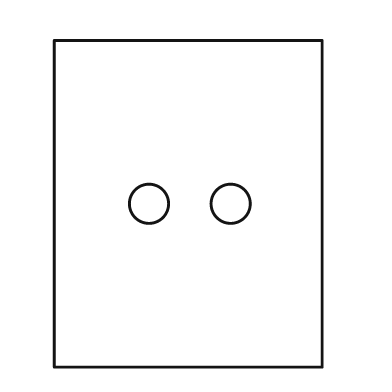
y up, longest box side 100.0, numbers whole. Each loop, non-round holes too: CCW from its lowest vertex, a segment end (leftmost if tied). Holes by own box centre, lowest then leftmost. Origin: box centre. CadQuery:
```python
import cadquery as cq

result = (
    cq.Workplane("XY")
    .moveTo(-41.0, -50.0)
    .lineTo(41.0, -50.0)
    .lineTo(41.0, 50.0)
    .lineTo(-41.0, 50.0)
    .close()
    .moveTo(-12.0, 0.0)
    .circle(6.0)
    .moveTo(13.0, 0.0)
    .circle(6.0)
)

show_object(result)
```